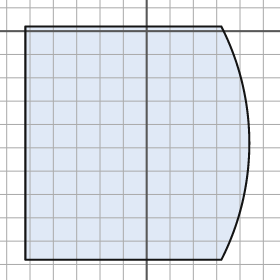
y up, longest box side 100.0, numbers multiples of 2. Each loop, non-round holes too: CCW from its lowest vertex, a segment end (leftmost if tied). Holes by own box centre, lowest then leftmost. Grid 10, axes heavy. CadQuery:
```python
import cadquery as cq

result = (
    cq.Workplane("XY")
    .moveTo(-52.0, -98.0)
    .lineTo(32.0, -98.0)
    .threePointArc((44.0, -48.0), (32.0, 2.0))
    .lineTo(-52.0, 2.0)
    .close()
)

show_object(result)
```